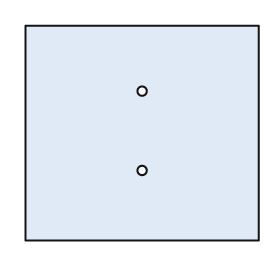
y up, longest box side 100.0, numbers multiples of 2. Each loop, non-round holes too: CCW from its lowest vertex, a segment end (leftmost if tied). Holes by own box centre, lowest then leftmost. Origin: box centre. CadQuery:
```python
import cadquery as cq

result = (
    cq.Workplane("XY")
    .moveTo(-50.0, -46.0)
    .lineTo(50.0, -46.0)
    .lineTo(50.0, 46.0)
    .lineTo(-50.0, 46.0)
    .close()
    .moveTo(0.0, -16.0)
    .circle(2.0)
    .moveTo(0.0, 18.0)
    .circle(2.0)
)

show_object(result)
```